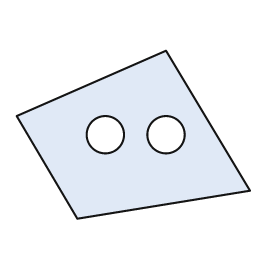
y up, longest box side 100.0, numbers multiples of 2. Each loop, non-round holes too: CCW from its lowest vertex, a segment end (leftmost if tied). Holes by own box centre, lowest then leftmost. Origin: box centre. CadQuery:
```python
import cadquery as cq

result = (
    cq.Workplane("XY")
    .moveTo(-24.0, -36.0)
    .lineTo(50.0, -24.0)
    .lineTo(14.0, 36.0)
    .lineTo(-50.0, 8.0)
    .close()
    .moveTo(-12.0, 0.0)
    .circle(8.0)
    .moveTo(14.0, 0.0)
    .circle(8.0)
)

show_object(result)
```